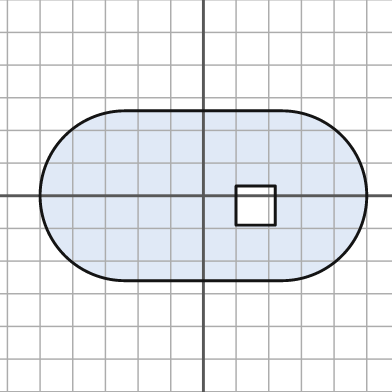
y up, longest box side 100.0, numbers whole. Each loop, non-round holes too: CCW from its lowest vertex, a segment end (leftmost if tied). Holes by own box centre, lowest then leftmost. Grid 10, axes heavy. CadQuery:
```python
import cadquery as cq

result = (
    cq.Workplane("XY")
    .moveTo(-24.0, -26.0)
    .lineTo(24.0, -26.0)
    .threePointArc((50.0, 0.0), (24.0, 26.0))
    .lineTo(-24.0, 26.0)
    .threePointArc((-50.0, 0.0), (-24.0, -26.0))
    .close()
    .moveTo(10.0, -9.0)
    .lineTo(22.0, -9.0)
    .lineTo(22.0, 3.0)
    .lineTo(10.0, 3.0)
    .close()
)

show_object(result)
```